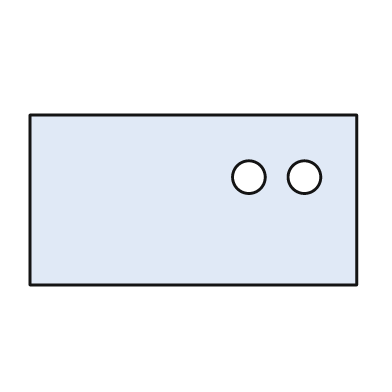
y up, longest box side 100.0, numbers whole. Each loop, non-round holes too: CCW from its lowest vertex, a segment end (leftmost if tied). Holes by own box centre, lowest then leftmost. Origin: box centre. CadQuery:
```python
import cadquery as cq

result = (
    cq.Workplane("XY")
    .moveTo(-50.0, -26.0)
    .lineTo(50.0, -26.0)
    .lineTo(50.0, 26.0)
    .lineTo(-50.0, 26.0)
    .close()
    .moveTo(17.0, 7.0)
    .circle(5.0)
    .moveTo(34.0, 7.0)
    .circle(5.0)
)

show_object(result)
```